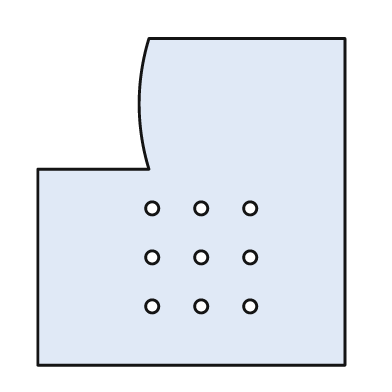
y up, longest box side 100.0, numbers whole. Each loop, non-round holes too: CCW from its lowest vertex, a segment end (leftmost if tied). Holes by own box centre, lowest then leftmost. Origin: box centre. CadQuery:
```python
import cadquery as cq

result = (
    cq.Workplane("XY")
    .moveTo(-47.0, -50.0)
    .lineTo(47.0, -50.0)
    .lineTo(47.0, 50.0)
    .lineTo(-13.0, 50.0)
    .threePointArc((-16.0, 30.0), (-13.0, 10.0))
    .lineTo(-47.0, 10.0)
    .close()
    .moveTo(-12.0, -32.0)
    .circle(2.0)
    .moveTo(3.0, -32.0)
    .circle(2.0)
    .moveTo(18.0, -32.0)
    .circle(2.0)
    .moveTo(-12.0, -17.0)
    .circle(2.0)
    .moveTo(3.0, -17.0)
    .circle(2.0)
    .moveTo(18.0, -17.0)
    .circle(2.0)
    .moveTo(-12.0, -2.0)
    .circle(2.0)
    .moveTo(3.0, -2.0)
    .circle(2.0)
    .moveTo(18.0, -2.0)
    .circle(2.0)
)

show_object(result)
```